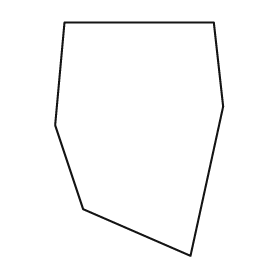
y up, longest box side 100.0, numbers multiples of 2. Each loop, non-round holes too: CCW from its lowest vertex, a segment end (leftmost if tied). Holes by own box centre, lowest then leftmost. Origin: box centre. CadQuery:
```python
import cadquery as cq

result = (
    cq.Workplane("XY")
    .moveTo(22.0, -50.0)
    .lineTo(36.0, 14.0)
    .lineTo(32.0, 50.0)
    .lineTo(-32.0, 50.0)
    .lineTo(-36.0, 6.0)
    .lineTo(-24.0, -30.0)
    .close()
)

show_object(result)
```